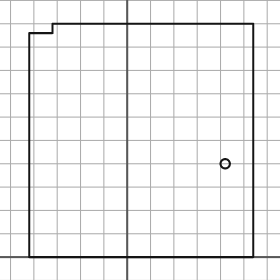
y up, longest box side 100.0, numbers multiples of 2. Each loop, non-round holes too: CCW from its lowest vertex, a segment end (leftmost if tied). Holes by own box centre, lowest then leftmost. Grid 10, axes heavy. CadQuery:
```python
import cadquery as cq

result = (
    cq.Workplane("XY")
    .moveTo(-42.0, 0.0)
    .lineTo(54.0, 0.0)
    .lineTo(54.0, 100.0)
    .lineTo(-32.0, 100.0)
    .lineTo(-32.0, 96.0)
    .lineTo(-42.0, 96.0)
    .close()
    .moveTo(42.0, 40.0)
    .circle(2.0)
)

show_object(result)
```